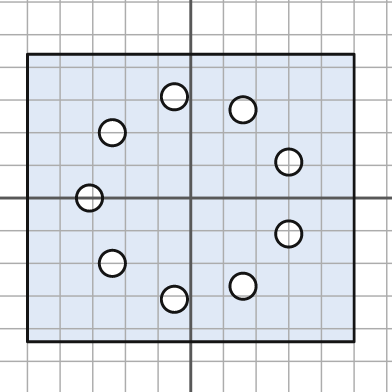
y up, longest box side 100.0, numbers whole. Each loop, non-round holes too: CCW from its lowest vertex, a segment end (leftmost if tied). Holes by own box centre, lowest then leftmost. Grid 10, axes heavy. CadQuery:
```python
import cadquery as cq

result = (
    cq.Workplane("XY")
    .moveTo(-50.0, -44.0)
    .lineTo(50.0, -44.0)
    .lineTo(50.0, 44.0)
    .lineTo(-50.0, 44.0)
    .close()
    .moveTo(-5.0, -31.0)
    .circle(4.0)
    .moveTo(16.0, -27.0)
    .circle(4.0)
    .moveTo(-24.0, -20.0)
    .circle(4.0)
    .moveTo(30.0, -11.0)
    .circle(4.0)
    .moveTo(-31.0, 0.0)
    .circle(4.0)
    .moveTo(30.0, 11.0)
    .circle(4.0)
    .moveTo(-24.0, 20.0)
    .circle(4.0)
    .moveTo(16.0, 27.0)
    .circle(4.0)
    .moveTo(-5.0, 31.0)
    .circle(4.0)
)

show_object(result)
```